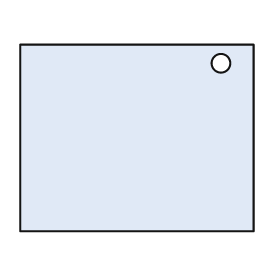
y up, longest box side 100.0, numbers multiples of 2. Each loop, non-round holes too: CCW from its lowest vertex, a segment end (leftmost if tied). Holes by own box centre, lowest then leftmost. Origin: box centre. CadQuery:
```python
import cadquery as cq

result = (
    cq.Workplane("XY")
    .moveTo(-50.0, -40.0)
    .lineTo(50.0, -40.0)
    .lineTo(50.0, 40.0)
    .lineTo(-50.0, 40.0)
    .close()
    .moveTo(36.0, 32.0)
    .circle(4.0)
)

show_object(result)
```